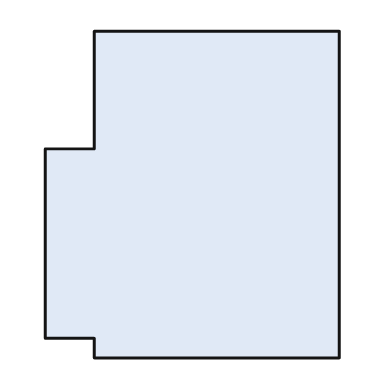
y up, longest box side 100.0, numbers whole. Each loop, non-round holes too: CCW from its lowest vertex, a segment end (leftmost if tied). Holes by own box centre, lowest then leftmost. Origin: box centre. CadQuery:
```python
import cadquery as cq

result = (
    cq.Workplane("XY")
    .moveTo(-30.0, -50.0)
    .lineTo(45.0, -50.0)
    .lineTo(45.0, 50.0)
    .lineTo(-30.0, 50.0)
    .lineTo(-30.0, 14.0)
    .lineTo(-45.0, 14.0)
    .lineTo(-45.0, -44.0)
    .lineTo(-30.0, -44.0)
    .close()
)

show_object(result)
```